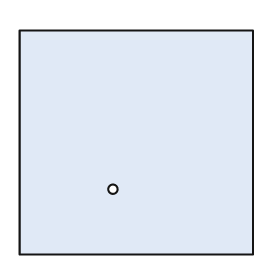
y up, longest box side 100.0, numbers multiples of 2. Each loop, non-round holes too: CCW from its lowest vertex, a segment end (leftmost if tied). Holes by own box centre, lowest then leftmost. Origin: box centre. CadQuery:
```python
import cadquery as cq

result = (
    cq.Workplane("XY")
    .moveTo(-50.0, -48.0)
    .lineTo(50.0, -48.0)
    .lineTo(50.0, 48.0)
    .lineTo(-50.0, 48.0)
    .close()
    .moveTo(-10.0, -20.0)
    .circle(2.0)
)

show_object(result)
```